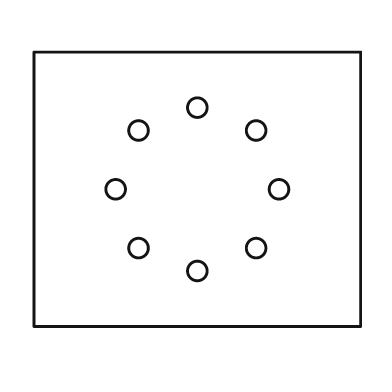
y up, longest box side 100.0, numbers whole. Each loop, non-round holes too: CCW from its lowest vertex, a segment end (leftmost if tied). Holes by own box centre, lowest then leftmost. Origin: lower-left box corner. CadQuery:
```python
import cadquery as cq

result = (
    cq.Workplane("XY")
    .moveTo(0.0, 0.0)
    .lineTo(100.0, 0.0)
    .lineTo(100.0, 84.0)
    .lineTo(0.0, 84.0)
    .close()
    .moveTo(50.0, 17.0)
    .circle(3.0)
    .moveTo(32.0, 24.0)
    .circle(3.0)
    .moveTo(68.0, 24.0)
    .circle(3.0)
    .moveTo(25.0, 42.0)
    .circle(3.0)
    .moveTo(75.0, 42.0)
    .circle(3.0)
    .moveTo(32.0, 60.0)
    .circle(3.0)
    .moveTo(68.0, 60.0)
    .circle(3.0)
    .moveTo(50.0, 67.0)
    .circle(3.0)
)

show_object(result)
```